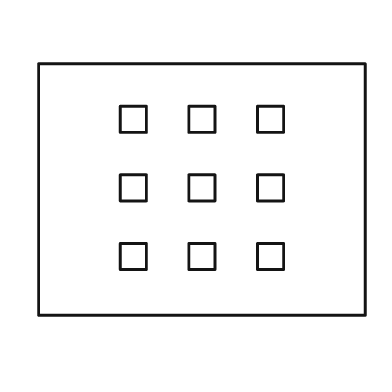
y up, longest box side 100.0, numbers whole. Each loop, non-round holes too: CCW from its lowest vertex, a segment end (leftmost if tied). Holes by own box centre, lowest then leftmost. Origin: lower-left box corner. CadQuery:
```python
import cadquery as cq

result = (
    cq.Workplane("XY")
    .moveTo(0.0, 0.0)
    .lineTo(100.0, 0.0)
    .lineTo(100.0, 77.0)
    .lineTo(0.0, 77.0)
    .close()
    .moveTo(25.0, 14.0)
    .lineTo(33.0, 14.0)
    .lineTo(33.0, 22.0)
    .lineTo(25.0, 22.0)
    .close()
    .moveTo(46.0, 14.0)
    .lineTo(54.0, 14.0)
    .lineTo(54.0, 22.0)
    .lineTo(46.0, 22.0)
    .close()
    .moveTo(67.0, 14.0)
    .lineTo(75.0, 14.0)
    .lineTo(75.0, 22.0)
    .lineTo(67.0, 22.0)
    .close()
    .moveTo(25.0, 35.0)
    .lineTo(33.0, 35.0)
    .lineTo(33.0, 43.0)
    .lineTo(25.0, 43.0)
    .close()
    .moveTo(46.0, 35.0)
    .lineTo(54.0, 35.0)
    .lineTo(54.0, 43.0)
    .lineTo(46.0, 43.0)
    .close()
    .moveTo(67.0, 35.0)
    .lineTo(75.0, 35.0)
    .lineTo(75.0, 43.0)
    .lineTo(67.0, 43.0)
    .close()
    .moveTo(25.0, 56.0)
    .lineTo(33.0, 56.0)
    .lineTo(33.0, 64.0)
    .lineTo(25.0, 64.0)
    .close()
    .moveTo(46.0, 56.0)
    .lineTo(54.0, 56.0)
    .lineTo(54.0, 64.0)
    .lineTo(46.0, 64.0)
    .close()
    .moveTo(67.0, 56.0)
    .lineTo(75.0, 56.0)
    .lineTo(75.0, 64.0)
    .lineTo(67.0, 64.0)
    .close()
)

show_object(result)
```